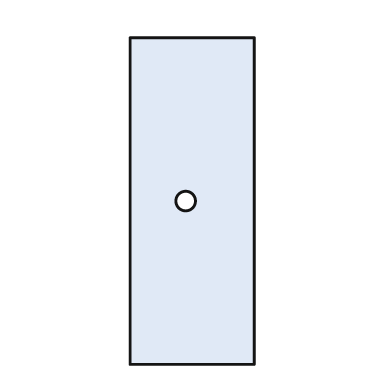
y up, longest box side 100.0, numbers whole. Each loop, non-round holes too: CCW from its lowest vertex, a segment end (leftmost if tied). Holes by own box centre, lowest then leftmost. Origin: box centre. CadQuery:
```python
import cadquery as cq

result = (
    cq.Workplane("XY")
    .moveTo(-19.0, -50.0)
    .lineTo(19.0, -50.0)
    .lineTo(19.0, 50.0)
    .lineTo(-19.0, 50.0)
    .close()
    .moveTo(-2.0, 0.0)
    .circle(3.0)
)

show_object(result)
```